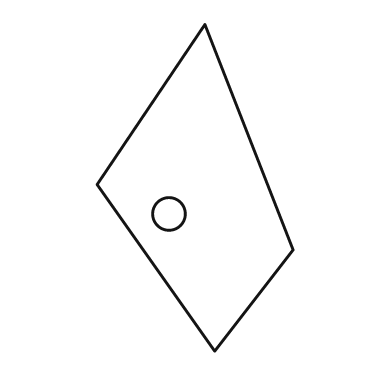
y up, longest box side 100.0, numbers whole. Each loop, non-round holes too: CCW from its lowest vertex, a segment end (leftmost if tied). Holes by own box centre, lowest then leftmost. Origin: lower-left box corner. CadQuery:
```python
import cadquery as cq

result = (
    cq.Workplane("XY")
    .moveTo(36.0, 0.0)
    .lineTo(60.0, 31.0)
    .lineTo(33.0, 100.0)
    .lineTo(0.0, 51.0)
    .close()
    .moveTo(22.0, 42.0)
    .circle(5.0)
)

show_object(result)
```